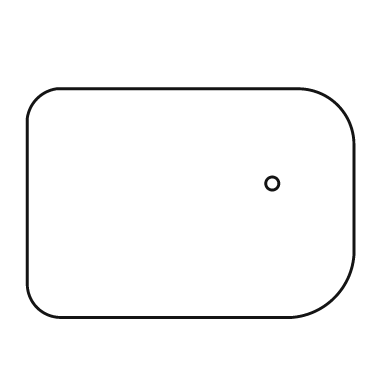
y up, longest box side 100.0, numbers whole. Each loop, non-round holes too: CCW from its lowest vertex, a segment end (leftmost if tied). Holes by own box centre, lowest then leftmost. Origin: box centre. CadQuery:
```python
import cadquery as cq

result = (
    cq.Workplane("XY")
    .moveTo(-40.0, -35.0)
    .lineTo(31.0, -35.0)
    .threePointArc((44.0, -29.0), (50.0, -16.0))
    .lineTo(50.0, 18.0)
    .threePointArc((45.0, 30.0), (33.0, 35.0))
    .lineTo(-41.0, 35.0)
    .threePointArc((-47.0, 32.0), (-50.0, 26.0))
    .lineTo(-50.0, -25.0)
    .threePointArc((-47.0, -32.0), (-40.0, -35.0))
    .close()
    .moveTo(25.0, 6.0)
    .circle(2.0)
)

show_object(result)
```